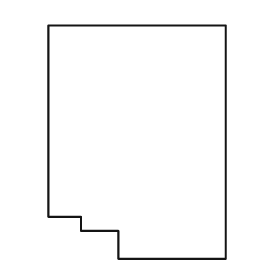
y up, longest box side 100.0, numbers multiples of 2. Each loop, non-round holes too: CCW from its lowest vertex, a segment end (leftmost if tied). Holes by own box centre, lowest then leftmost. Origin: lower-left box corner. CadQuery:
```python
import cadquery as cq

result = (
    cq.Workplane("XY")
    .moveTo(30.0, 0.0)
    .lineTo(76.0, 0.0)
    .lineTo(76.0, 100.0)
    .lineTo(0.0, 100.0)
    .lineTo(0.0, 18.0)
    .lineTo(14.0, 18.0)
    .lineTo(14.0, 12.0)
    .lineTo(30.0, 12.0)
    .close()
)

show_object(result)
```